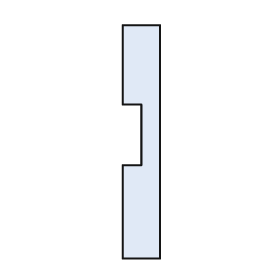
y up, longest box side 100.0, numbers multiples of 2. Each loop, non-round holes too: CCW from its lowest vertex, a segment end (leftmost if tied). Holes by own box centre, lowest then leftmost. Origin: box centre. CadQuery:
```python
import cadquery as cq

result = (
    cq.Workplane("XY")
    .moveTo(-8.0, -50.0)
    .lineTo(8.0, -50.0)
    .lineTo(8.0, 50.0)
    .lineTo(-8.0, 50.0)
    .lineTo(-8.0, 16.0)
    .lineTo(0.0, 16.0)
    .lineTo(0.0, -10.0)
    .lineTo(-8.0, -10.0)
    .close()
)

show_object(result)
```